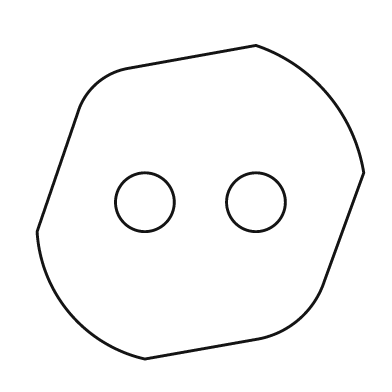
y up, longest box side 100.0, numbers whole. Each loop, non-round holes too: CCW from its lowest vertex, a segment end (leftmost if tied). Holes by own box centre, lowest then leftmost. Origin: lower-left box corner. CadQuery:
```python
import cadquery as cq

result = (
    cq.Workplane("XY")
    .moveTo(33.0, 0.0)
    .lineTo(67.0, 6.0)
    .threePointArc((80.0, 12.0), (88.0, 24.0))
    .lineTo(100.0, 57.0)
    .threePointArc((89.0, 81.0), (67.0, 96.0))
    .lineTo(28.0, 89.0)
    .threePointArc((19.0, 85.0), (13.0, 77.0))
    .lineTo(0.0, 39.0)
    .threePointArc((10.0, 14.0), (33.0, 0.0))
    .close()
    .moveTo(33.0, 48.0)
    .circle(9.0)
    .moveTo(67.0, 48.0)
    .circle(9.0)
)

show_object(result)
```